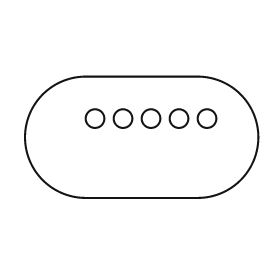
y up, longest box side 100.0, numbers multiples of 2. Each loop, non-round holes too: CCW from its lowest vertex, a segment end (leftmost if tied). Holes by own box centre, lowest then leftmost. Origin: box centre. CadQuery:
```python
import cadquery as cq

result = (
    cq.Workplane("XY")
    .moveTo(-24.0, -26.0)
    .lineTo(24.0, -26.0)
    .threePointArc((50.0, 0.0), (24.0, 26.0))
    .lineTo(-24.0, 26.0)
    .threePointArc((-50.0, 0.0), (-24.0, -26.0))
    .close()
    .moveTo(-20.0, 8.0)
    .circle(4.0)
    .moveTo(-8.0, 8.0)
    .circle(4.0)
    .moveTo(4.0, 8.0)
    .circle(4.0)
    .moveTo(16.0, 8.0)
    .circle(4.0)
    .moveTo(28.0, 8.0)
    .circle(4.0)
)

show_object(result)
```